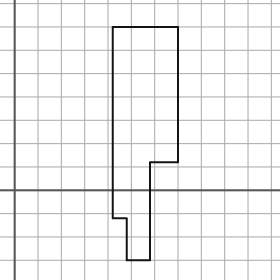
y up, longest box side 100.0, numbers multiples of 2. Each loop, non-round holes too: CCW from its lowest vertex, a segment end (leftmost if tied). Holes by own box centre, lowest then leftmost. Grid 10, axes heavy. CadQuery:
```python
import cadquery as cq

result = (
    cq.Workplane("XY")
    .moveTo(48.0, -30.0)
    .lineTo(58.0, -30.0)
    .lineTo(58.0, 12.0)
    .lineTo(70.0, 12.0)
    .lineTo(70.0, 70.0)
    .lineTo(42.0, 70.0)
    .lineTo(42.0, -12.0)
    .lineTo(48.0, -12.0)
    .close()
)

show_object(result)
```